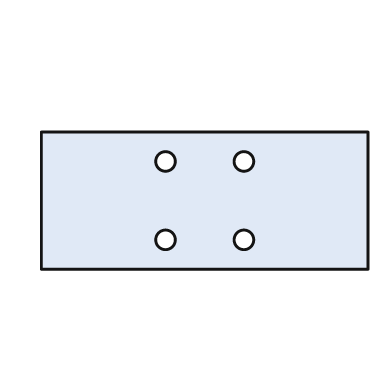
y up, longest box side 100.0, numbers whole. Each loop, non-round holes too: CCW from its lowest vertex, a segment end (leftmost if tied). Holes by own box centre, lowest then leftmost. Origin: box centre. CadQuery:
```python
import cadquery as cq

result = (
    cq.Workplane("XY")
    .moveTo(-50.0, -21.0)
    .lineTo(50.0, -21.0)
    .lineTo(50.0, 21.0)
    .lineTo(-50.0, 21.0)
    .close()
    .moveTo(-12.0, -12.0)
    .circle(3.0)
    .moveTo(12.0, -12.0)
    .circle(3.0)
    .moveTo(-12.0, 12.0)
    .circle(3.0)
    .moveTo(12.0, 12.0)
    .circle(3.0)
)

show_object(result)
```